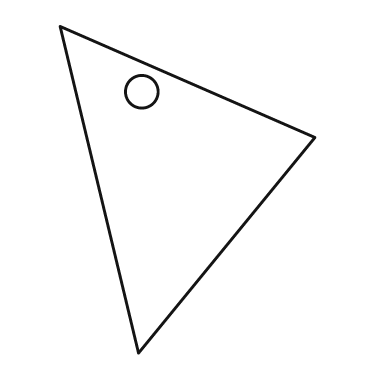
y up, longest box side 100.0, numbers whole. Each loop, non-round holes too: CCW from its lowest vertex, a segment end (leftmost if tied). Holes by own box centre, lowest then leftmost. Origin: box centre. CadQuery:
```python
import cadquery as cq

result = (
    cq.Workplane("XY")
    .moveTo(-15.0, -50.0)
    .lineTo(39.0, 16.0)
    .lineTo(-39.0, 50.0)
    .close()
    .moveTo(-14.0, 30.0)
    .circle(5.0)
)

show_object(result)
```